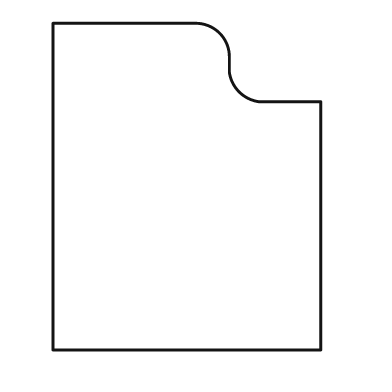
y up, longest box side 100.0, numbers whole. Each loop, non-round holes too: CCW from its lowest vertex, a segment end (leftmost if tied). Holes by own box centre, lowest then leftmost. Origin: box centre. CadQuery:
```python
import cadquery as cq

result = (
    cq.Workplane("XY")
    .moveTo(-41.0, -50.0)
    .lineTo(41.0, -50.0)
    .lineTo(41.0, 26.0)
    .lineTo(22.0, 26.0)
    .threePointArc((16.0, 29.0), (13.0, 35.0))
    .lineTo(13.0, 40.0)
    .threePointArc((10.0, 47.0), (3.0, 50.0))
    .lineTo(-41.0, 50.0)
    .close()
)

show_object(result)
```